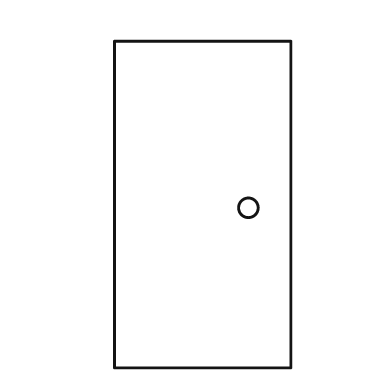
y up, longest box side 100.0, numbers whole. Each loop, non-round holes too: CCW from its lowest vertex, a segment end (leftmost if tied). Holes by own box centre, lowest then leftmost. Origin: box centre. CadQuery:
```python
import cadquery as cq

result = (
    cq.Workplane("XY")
    .moveTo(-27.0, -50.0)
    .lineTo(27.0, -50.0)
    .lineTo(27.0, 50.0)
    .lineTo(-27.0, 50.0)
    .close()
    .moveTo(14.0, -1.0)
    .circle(3.0)
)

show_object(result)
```